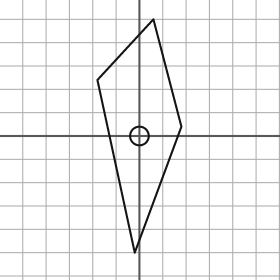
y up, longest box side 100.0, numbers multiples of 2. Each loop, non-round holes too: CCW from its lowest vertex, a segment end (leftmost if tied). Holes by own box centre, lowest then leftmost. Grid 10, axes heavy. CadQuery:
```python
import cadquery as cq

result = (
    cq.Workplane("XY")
    .moveTo(-2.0, -50.0)
    .lineTo(18.0, 4.0)
    .lineTo(6.0, 50.0)
    .lineTo(-18.0, 24.0)
    .close()
    .moveTo(0.0, 0.0)
    .circle(4.0)
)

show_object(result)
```